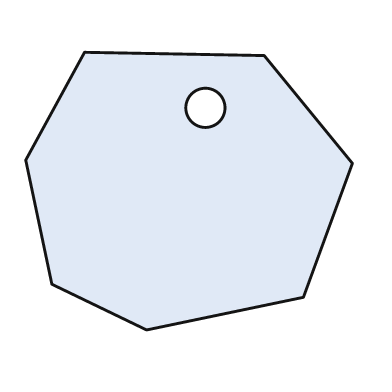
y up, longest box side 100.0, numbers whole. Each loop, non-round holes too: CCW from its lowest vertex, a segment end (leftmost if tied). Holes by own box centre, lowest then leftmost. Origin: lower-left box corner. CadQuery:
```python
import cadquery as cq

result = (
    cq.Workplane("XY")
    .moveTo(37.0, 0.0)
    .lineTo(85.0, 10.0)
    .lineTo(100.0, 51.0)
    .lineTo(73.0, 84.0)
    .lineTo(18.0, 85.0)
    .lineTo(0.0, 52.0)
    .lineTo(8.0, 14.0)
    .close()
    .moveTo(55.0, 68.0)
    .circle(6.0)
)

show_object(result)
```